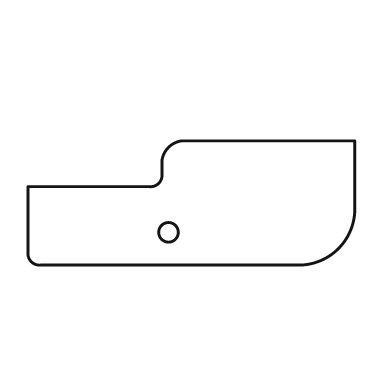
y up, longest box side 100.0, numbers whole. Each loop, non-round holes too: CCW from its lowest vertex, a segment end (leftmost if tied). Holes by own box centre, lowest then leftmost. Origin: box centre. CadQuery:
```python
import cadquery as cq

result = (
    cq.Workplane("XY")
    .moveTo(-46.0, -19.0)
    .lineTo(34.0, -19.0)
    .threePointArc((45.0, -14.0), (50.0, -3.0))
    .lineTo(50.0, 19.0)
    .lineTo(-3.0, 19.0)
    .threePointArc((-7.0, 17.0), (-9.0, 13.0))
    .lineTo(-9.0, 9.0)
    .threePointArc((-10.0, 6.0), (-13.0, 5.0))
    .lineTo(-50.0, 5.0)
    .lineTo(-50.0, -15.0)
    .threePointArc((-49.0, -18.0), (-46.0, -19.0))
    .close()
    .moveTo(-7.0, -9.0)
    .circle(3.0)
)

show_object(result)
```